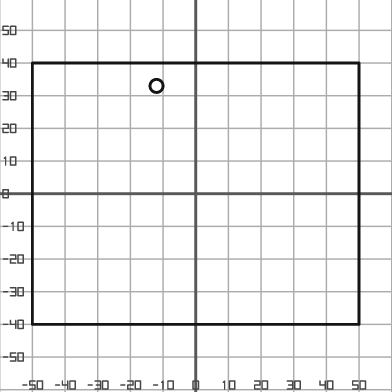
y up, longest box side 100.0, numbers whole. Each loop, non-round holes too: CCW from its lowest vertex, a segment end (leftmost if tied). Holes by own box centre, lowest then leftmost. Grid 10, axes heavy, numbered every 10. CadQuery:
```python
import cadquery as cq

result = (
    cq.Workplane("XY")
    .moveTo(-50.0, -40.0)
    .lineTo(50.0, -40.0)
    .lineTo(50.0, 40.0)
    .lineTo(-50.0, 40.0)
    .close()
    .moveTo(-12.0, 33.0)
    .circle(2.0)
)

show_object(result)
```